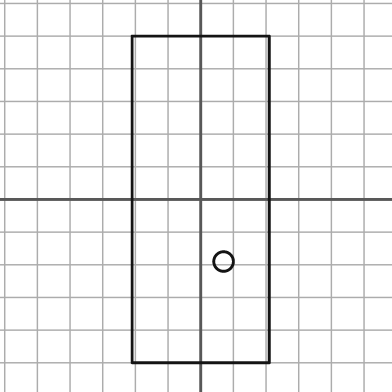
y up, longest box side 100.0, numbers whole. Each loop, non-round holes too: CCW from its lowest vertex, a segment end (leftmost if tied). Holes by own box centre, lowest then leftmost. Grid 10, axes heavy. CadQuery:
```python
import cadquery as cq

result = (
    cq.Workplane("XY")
    .moveTo(-21.0, -50.0)
    .lineTo(21.0, -50.0)
    .lineTo(21.0, 50.0)
    .lineTo(-21.0, 50.0)
    .close()
    .moveTo(7.0, -19.0)
    .circle(3.0)
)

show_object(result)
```